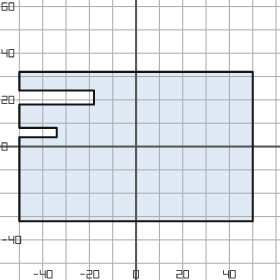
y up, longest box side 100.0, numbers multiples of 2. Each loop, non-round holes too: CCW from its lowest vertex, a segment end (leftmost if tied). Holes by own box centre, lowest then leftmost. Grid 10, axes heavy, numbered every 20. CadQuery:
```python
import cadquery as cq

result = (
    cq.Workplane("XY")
    .moveTo(-50.0, -32.0)
    .lineTo(50.0, -32.0)
    .lineTo(50.0, 32.0)
    .lineTo(-50.0, 32.0)
    .lineTo(-50.0, 24.0)
    .lineTo(-18.0, 24.0)
    .lineTo(-18.0, 18.0)
    .lineTo(-50.0, 18.0)
    .lineTo(-50.0, 8.0)
    .lineTo(-34.0, 8.0)
    .lineTo(-34.0, 4.0)
    .lineTo(-50.0, 4.0)
    .close()
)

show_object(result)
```